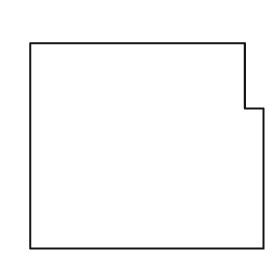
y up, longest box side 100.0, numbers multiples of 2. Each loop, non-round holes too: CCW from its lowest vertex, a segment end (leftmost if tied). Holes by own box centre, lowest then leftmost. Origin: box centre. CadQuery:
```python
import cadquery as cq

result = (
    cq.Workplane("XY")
    .moveTo(-50.0, -44.0)
    .lineTo(50.0, -44.0)
    .lineTo(50.0, 16.0)
    .lineTo(42.0, 16.0)
    .lineTo(42.0, 44.0)
    .lineTo(-50.0, 44.0)
    .close()
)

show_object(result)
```